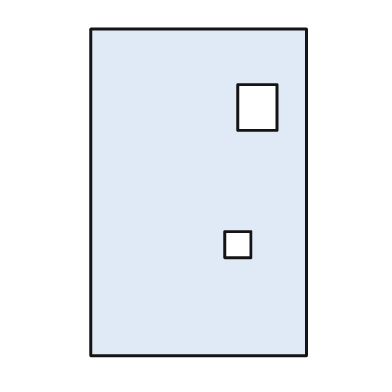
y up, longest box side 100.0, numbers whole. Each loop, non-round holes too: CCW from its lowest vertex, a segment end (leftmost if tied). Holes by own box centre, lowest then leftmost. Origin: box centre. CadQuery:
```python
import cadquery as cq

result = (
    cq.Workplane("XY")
    .moveTo(-33.0, -50.0)
    .lineTo(33.0, -50.0)
    .lineTo(33.0, 50.0)
    .lineTo(-33.0, 50.0)
    .close()
    .moveTo(8.0, -20.0)
    .lineTo(16.0, -20.0)
    .lineTo(16.0, -12.0)
    .lineTo(8.0, -12.0)
    .close()
    .moveTo(12.0, 19.0)
    .lineTo(24.0, 19.0)
    .lineTo(24.0, 33.0)
    .lineTo(12.0, 33.0)
    .close()
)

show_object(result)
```